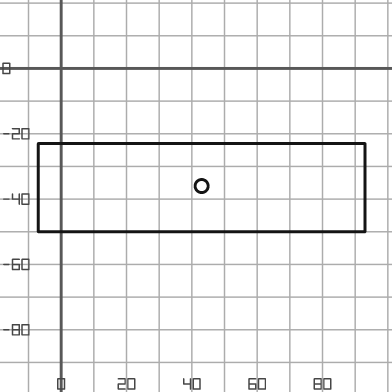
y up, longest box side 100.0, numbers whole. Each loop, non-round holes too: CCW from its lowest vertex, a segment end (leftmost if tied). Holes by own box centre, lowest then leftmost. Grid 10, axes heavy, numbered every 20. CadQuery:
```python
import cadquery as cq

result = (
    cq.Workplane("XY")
    .moveTo(-7.0, -50.0)
    .lineTo(93.0, -50.0)
    .lineTo(93.0, -23.0)
    .lineTo(-7.0, -23.0)
    .close()
    .moveTo(43.0, -36.0)
    .circle(2.0)
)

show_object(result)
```